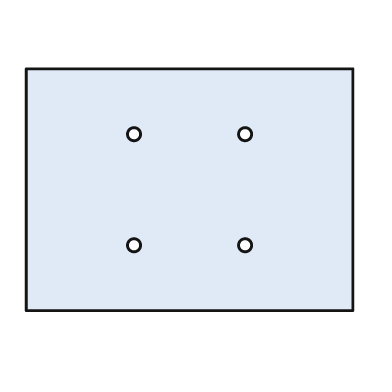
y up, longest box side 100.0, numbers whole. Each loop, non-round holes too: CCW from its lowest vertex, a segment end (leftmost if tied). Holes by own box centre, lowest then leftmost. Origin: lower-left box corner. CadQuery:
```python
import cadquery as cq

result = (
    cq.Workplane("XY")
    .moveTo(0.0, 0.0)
    .lineTo(100.0, 0.0)
    .lineTo(100.0, 74.0)
    .lineTo(0.0, 74.0)
    .close()
    .moveTo(33.0, 20.0)
    .circle(2.0)
    .moveTo(67.0, 20.0)
    .circle(2.0)
    .moveTo(33.0, 54.0)
    .circle(2.0)
    .moveTo(67.0, 54.0)
    .circle(2.0)
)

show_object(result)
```